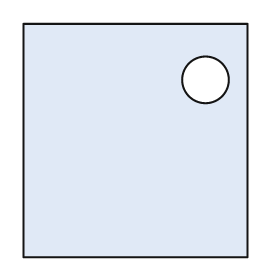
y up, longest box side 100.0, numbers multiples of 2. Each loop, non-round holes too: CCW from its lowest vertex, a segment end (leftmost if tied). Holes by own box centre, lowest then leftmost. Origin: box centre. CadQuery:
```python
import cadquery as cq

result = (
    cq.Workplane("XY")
    .moveTo(-48.0, -50.0)
    .lineTo(48.0, -50.0)
    .lineTo(48.0, 50.0)
    .lineTo(-48.0, 50.0)
    .close()
    .moveTo(30.0, 26.0)
    .circle(10.0)
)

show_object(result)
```